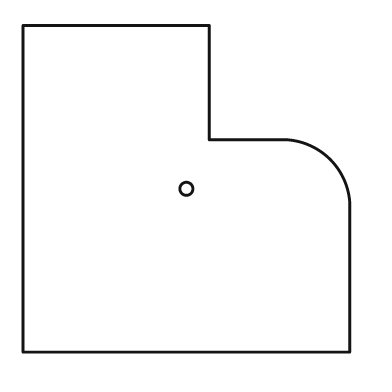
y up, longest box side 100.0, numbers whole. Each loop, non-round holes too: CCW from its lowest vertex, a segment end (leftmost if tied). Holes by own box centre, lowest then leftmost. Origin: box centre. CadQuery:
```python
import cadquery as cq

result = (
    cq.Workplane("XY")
    .moveTo(-50.0, -50.0)
    .lineTo(50.0, -50.0)
    .lineTo(50.0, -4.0)
    .threePointArc((44.0, 9.0), (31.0, 15.0))
    .lineTo(7.0, 15.0)
    .lineTo(7.0, 50.0)
    .lineTo(-50.0, 50.0)
    .close()
    .moveTo(0.0, 0.0)
    .circle(2.0)
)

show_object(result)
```